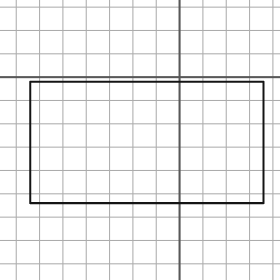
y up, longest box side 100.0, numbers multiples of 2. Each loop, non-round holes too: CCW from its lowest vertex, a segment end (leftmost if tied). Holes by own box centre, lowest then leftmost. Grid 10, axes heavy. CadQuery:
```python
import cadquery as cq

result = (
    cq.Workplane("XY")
    .moveTo(-64.0, -54.0)
    .lineTo(36.0, -54.0)
    .lineTo(36.0, -2.0)
    .lineTo(-64.0, -2.0)
    .close()
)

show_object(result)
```